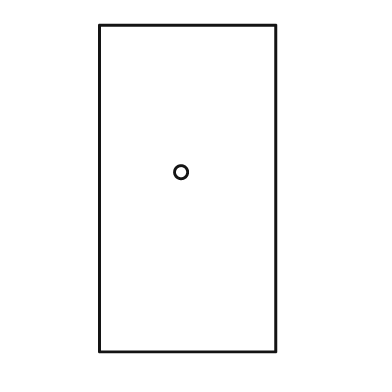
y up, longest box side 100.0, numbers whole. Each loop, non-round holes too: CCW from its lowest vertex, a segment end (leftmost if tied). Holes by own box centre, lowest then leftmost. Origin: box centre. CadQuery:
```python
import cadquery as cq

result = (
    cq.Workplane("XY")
    .moveTo(-27.0, -50.0)
    .lineTo(27.0, -50.0)
    .lineTo(27.0, 50.0)
    .lineTo(-27.0, 50.0)
    .close()
    .moveTo(-2.0, 5.0)
    .circle(2.0)
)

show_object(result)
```